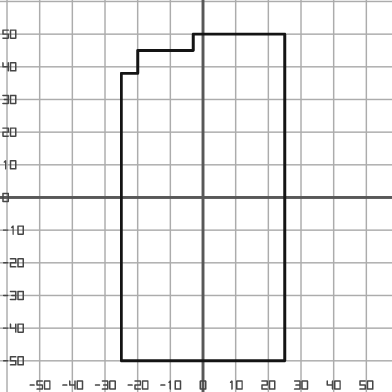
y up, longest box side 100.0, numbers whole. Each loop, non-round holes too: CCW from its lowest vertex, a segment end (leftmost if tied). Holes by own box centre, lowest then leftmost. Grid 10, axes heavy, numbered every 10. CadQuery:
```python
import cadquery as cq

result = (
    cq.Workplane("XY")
    .moveTo(-25.0, -50.0)
    .lineTo(25.0, -50.0)
    .lineTo(25.0, 50.0)
    .lineTo(-3.0, 50.0)
    .lineTo(-3.0, 45.0)
    .lineTo(-20.0, 45.0)
    .lineTo(-20.0, 38.0)
    .lineTo(-25.0, 38.0)
    .close()
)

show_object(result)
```